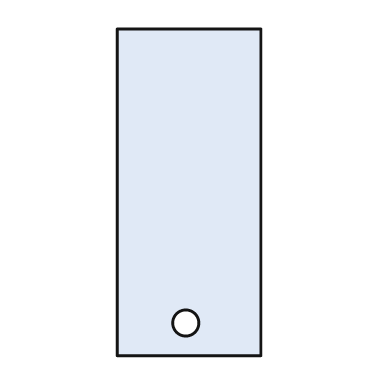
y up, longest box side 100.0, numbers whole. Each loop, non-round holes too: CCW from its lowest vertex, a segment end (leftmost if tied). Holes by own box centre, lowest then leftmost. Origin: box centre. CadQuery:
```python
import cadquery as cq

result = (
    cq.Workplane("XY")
    .moveTo(-22.0, -50.0)
    .lineTo(22.0, -50.0)
    .lineTo(22.0, 50.0)
    .lineTo(-22.0, 50.0)
    .close()
    .moveTo(-1.0, -40.0)
    .circle(4.0)
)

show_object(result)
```